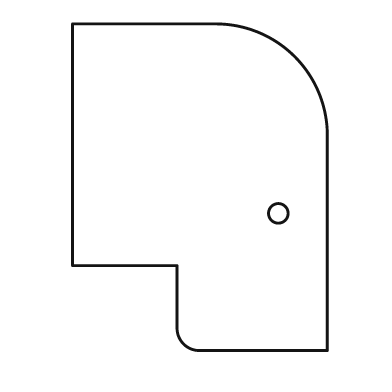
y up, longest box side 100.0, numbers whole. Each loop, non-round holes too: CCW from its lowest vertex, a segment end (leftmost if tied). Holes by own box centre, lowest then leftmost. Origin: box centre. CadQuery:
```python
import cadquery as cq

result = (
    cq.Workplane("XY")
    .moveTo(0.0, -50.0)
    .lineTo(39.0, -50.0)
    .lineTo(39.0, 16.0)
    .threePointArc((29.0, 40.0), (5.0, 50.0))
    .lineTo(-39.0, 50.0)
    .lineTo(-39.0, -24.0)
    .lineTo(-7.0, -24.0)
    .lineTo(-7.0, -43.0)
    .threePointArc((-5.0, -48.0), (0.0, -50.0))
    .close()
    .moveTo(24.0, -8.0)
    .circle(3.0)
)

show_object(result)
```